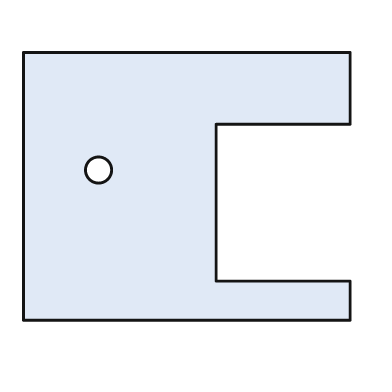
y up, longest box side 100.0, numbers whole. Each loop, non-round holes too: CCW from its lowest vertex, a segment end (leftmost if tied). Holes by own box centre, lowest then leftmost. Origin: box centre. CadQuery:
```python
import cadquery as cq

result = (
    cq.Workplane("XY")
    .moveTo(-50.0, -41.0)
    .lineTo(50.0, -41.0)
    .lineTo(50.0, -29.0)
    .lineTo(9.0, -29.0)
    .lineTo(9.0, 19.0)
    .lineTo(50.0, 19.0)
    .lineTo(50.0, 41.0)
    .lineTo(-50.0, 41.0)
    .close()
    .moveTo(-27.0, 5.0)
    .circle(4.0)
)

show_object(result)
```